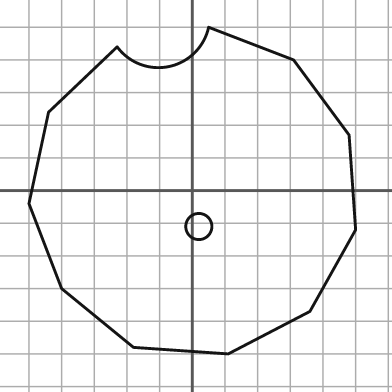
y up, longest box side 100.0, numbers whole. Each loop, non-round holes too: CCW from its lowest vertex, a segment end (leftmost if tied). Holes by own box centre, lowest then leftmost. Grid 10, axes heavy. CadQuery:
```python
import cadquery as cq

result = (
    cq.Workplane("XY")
    .moveTo(11.0, -50.0)
    .lineTo(36.0, -37.0)
    .lineTo(50.0, -12.0)
    .lineTo(48.0, 17.0)
    .lineTo(31.0, 40.0)
    .lineTo(5.0, 50.0)
    .threePointArc((-7.0, 38.0), (-23.0, 44.0))
    .lineTo(-44.0, 24.0)
    .lineTo(-50.0, -4.0)
    .lineTo(-40.0, -30.0)
    .lineTo(-18.0, -48.0)
    .close()
    .moveTo(2.0, -11.0)
    .circle(4.0)
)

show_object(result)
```